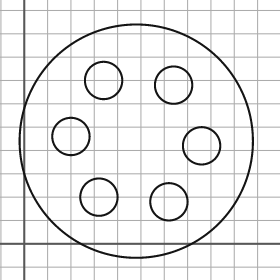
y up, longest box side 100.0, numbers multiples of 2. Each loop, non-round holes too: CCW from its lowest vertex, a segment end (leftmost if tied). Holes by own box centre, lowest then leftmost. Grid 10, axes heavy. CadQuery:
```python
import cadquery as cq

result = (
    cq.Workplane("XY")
    .moveTo(48.0, 44.0)
    .circle(50.0)
    .moveTo(62.0, 18.0)
    .circle(8.0)
    .moveTo(32.0, 20.0)
    .circle(8.0)
    .moveTo(76.0, 42.0)
    .circle(8.0)
    .moveTo(20.0, 46.0)
    .circle(8.0)
    .moveTo(64.0, 68.0)
    .circle(8.0)
    .moveTo(34.0, 70.0)
    .circle(8.0)
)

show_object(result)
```